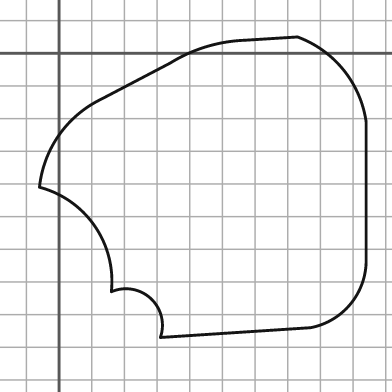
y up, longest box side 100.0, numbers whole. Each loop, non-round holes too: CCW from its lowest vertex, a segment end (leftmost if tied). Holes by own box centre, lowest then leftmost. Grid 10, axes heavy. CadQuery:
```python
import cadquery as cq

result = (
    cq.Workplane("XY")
    .moveTo(31.0, -87.0)
    .lineTo(77.0, -84.0)
    .threePointArc((89.0, -77.0), (94.0, -64.0))
    .lineTo(94.0, -21.0)
    .threePointArc((87.0, -5.0), (73.0, 5.0))
    .lineTo(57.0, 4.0)
    .threePointArc((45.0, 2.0), (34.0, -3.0))
    .lineTo(13.0, -14.0)
    .threePointArc((0.0, -25.0), (-6.0, -41.0))
    .threePointArc((11.0, -53.0), (16.0, -73.0))
    .threePointArc((28.0, -75.0), (31.0, -87.0))
    .close()
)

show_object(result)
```